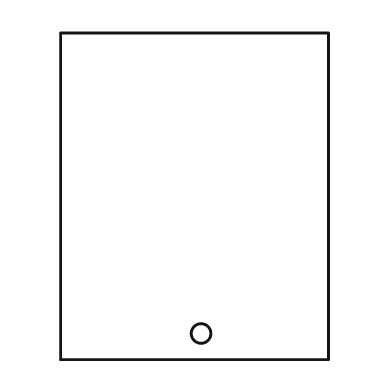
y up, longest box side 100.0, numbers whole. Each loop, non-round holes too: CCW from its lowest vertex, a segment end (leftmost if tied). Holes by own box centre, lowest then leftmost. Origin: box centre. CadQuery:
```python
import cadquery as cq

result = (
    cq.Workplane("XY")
    .moveTo(-41.0, -50.0)
    .lineTo(41.0, -50.0)
    .lineTo(41.0, 50.0)
    .lineTo(-41.0, 50.0)
    .close()
    .moveTo(2.0, -42.0)
    .circle(3.0)
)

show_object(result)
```